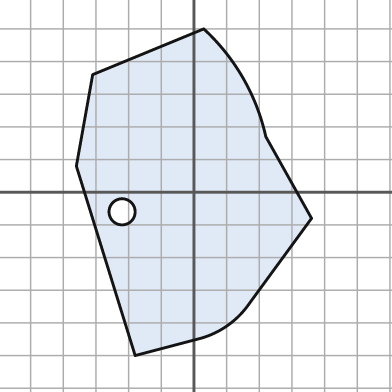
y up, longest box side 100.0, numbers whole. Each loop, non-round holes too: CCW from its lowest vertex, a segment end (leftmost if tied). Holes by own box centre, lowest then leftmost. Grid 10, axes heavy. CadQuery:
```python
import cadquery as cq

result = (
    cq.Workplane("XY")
    .moveTo(-18.0, -50.0)
    .lineTo(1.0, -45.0)
    .threePointArc((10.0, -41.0), (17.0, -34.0))
    .lineTo(36.0, -8.0)
    .lineTo(22.0, 17.0)
    .threePointArc((15.0, 35.0), (3.0, 50.0))
    .lineTo(-31.0, 36.0)
    .lineTo(-36.0, 8.0)
    .close()
    .moveTo(-22.0, -6.0)
    .circle(4.0)
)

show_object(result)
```